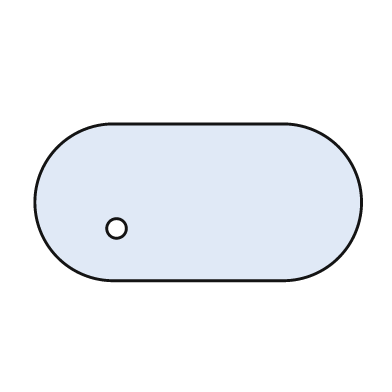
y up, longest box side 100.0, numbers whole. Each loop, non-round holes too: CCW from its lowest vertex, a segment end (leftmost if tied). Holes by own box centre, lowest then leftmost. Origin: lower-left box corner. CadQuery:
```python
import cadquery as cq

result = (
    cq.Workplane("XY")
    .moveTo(24.0, 0.0)
    .lineTo(76.0, 0.0)
    .threePointArc((100.0, 24.0), (76.0, 48.0))
    .lineTo(24.0, 48.0)
    .threePointArc((0.0, 24.0), (24.0, 0.0))
    .close()
    .moveTo(25.0, 16.0)
    .circle(3.0)
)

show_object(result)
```